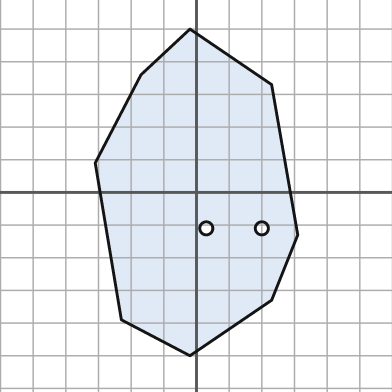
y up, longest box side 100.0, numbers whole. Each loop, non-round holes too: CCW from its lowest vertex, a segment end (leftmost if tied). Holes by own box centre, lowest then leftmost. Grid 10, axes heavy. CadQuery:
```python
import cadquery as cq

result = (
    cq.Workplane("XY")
    .moveTo(-2.0, -50.0)
    .lineTo(23.0, -33.0)
    .lineTo(31.0, -13.0)
    .lineTo(23.0, 33.0)
    .lineTo(-2.0, 50.0)
    .lineTo(-17.0, 36.0)
    .lineTo(-31.0, 9.0)
    .lineTo(-23.0, -39.0)
    .close()
    .moveTo(3.0, -11.0)
    .circle(2.0)
    .moveTo(20.0, -11.0)
    .circle(2.0)
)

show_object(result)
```